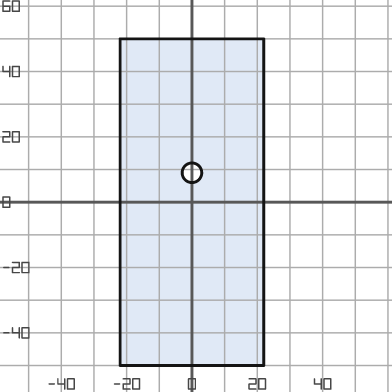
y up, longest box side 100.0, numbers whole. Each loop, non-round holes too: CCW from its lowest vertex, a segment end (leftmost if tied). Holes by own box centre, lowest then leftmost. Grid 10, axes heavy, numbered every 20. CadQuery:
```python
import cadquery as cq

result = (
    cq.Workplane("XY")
    .moveTo(-22.0, -50.0)
    .lineTo(22.0, -50.0)
    .lineTo(22.0, 50.0)
    .lineTo(-22.0, 50.0)
    .close()
    .moveTo(0.0, 9.0)
    .circle(3.0)
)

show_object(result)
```